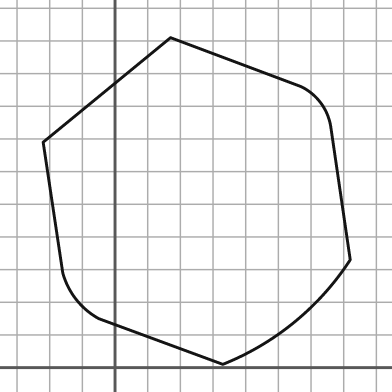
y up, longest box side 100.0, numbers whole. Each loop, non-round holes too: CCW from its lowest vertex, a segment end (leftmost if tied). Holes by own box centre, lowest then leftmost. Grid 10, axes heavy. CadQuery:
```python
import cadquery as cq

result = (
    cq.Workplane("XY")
    .moveTo(33.0, 1.0)
    .threePointArc((55.0, 14.0), (72.0, 33.0))
    .lineTo(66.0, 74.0)
    .threePointArc((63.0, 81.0), (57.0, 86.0))
    .lineTo(17.0, 101.0)
    .lineTo(-22.0, 69.0)
    .lineTo(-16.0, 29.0)
    .threePointArc((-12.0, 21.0), (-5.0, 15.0))
    .close()
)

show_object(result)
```